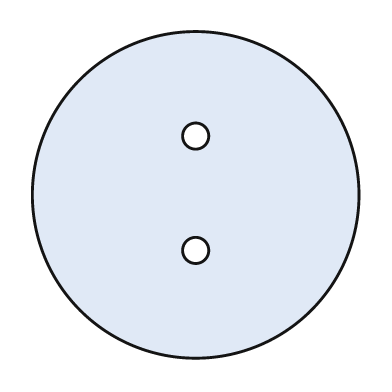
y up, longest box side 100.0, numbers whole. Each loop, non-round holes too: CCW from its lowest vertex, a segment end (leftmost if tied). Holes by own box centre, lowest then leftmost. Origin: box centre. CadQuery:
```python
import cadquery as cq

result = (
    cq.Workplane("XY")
    .moveTo(0.0, 0.0)
    .circle(50.0)
    .moveTo(0.0, -17.0)
    .circle(4.0)
    .moveTo(0.0, 18.0)
    .circle(4.0)
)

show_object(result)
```